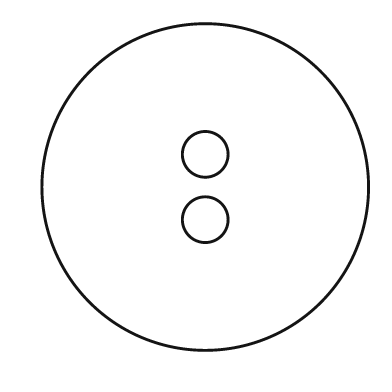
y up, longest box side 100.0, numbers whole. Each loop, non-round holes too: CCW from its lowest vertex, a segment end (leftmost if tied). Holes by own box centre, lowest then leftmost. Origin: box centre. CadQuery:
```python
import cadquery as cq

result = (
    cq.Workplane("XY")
    .moveTo(0.0, 0.0)
    .circle(50.0)
    .moveTo(0.0, -10.0)
    .circle(7.0)
    .moveTo(0.0, 10.0)
    .circle(7.0)
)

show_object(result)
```